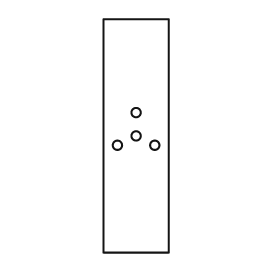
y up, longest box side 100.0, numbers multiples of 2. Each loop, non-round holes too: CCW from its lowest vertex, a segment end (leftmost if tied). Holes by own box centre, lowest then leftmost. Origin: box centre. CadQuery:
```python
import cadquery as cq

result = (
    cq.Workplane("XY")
    .moveTo(-14.0, -50.0)
    .lineTo(14.0, -50.0)
    .lineTo(14.0, 50.0)
    .lineTo(-14.0, 50.0)
    .close()
    .moveTo(-8.0, -4.0)
    .circle(2.0)
    .moveTo(8.0, -4.0)
    .circle(2.0)
    .moveTo(0.0, 0.0)
    .circle(2.0)
    .moveTo(0.0, 10.0)
    .circle(2.0)
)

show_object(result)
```